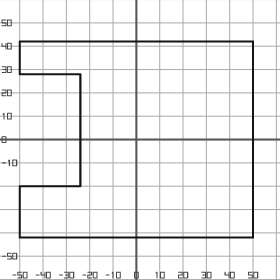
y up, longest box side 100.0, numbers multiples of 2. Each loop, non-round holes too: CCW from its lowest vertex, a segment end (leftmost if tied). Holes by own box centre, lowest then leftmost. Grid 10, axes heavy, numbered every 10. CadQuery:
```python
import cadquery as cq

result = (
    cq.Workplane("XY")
    .moveTo(-50.0, -42.0)
    .lineTo(50.0, -42.0)
    .lineTo(50.0, 42.0)
    .lineTo(-50.0, 42.0)
    .lineTo(-50.0, 28.0)
    .lineTo(-24.0, 28.0)
    .lineTo(-24.0, -20.0)
    .lineTo(-50.0, -20.0)
    .close()
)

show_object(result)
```